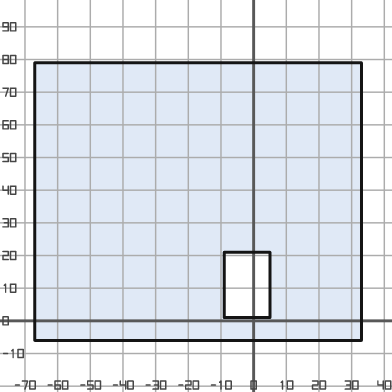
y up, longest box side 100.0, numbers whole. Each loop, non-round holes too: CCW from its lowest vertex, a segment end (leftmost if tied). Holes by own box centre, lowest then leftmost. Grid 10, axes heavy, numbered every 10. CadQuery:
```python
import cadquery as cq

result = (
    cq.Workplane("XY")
    .moveTo(-67.0, -6.0)
    .lineTo(33.0, -6.0)
    .lineTo(33.0, 79.0)
    .lineTo(-67.0, 79.0)
    .close()
    .moveTo(-9.0, 1.0)
    .lineTo(5.0, 1.0)
    .lineTo(5.0, 21.0)
    .lineTo(-9.0, 21.0)
    .close()
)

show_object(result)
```